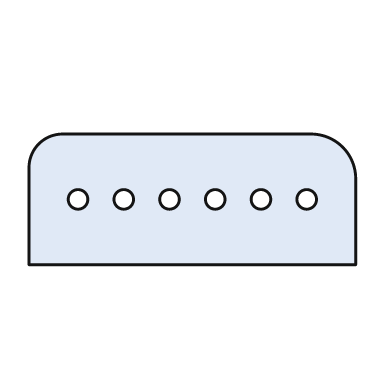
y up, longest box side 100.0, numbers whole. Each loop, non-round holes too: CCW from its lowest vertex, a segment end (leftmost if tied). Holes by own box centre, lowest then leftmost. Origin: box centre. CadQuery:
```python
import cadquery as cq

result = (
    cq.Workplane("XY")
    .moveTo(-50.0, -20.0)
    .lineTo(50.0, -20.0)
    .lineTo(50.0, 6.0)
    .threePointArc((46.0, 16.0), (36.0, 20.0))
    .lineTo(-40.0, 20.0)
    .threePointArc((-47.0, 17.0), (-50.0, 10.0))
    .close()
    .moveTo(-35.0, 0.0)
    .circle(3.0)
    .moveTo(-21.0, 0.0)
    .circle(3.0)
    .moveTo(-7.0, 0.0)
    .circle(3.0)
    .moveTo(7.0, 0.0)
    .circle(3.0)
    .moveTo(21.0, 0.0)
    .circle(3.0)
    .moveTo(35.0, 0.0)
    .circle(3.0)
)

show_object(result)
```